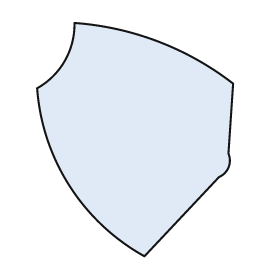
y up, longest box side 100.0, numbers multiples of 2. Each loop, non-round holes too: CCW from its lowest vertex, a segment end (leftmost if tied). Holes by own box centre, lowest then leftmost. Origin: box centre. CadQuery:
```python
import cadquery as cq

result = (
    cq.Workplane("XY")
    .moveTo(4.0, -50.0)
    .lineTo(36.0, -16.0)
    .threePointArc((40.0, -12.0), (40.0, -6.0))
    .lineTo(42.0, 24.0)
    .threePointArc((10.0, 42.0), (-26.0, 50.0))
    .threePointArc((-30.0, 34.0), (-42.0, 22.0))
    .threePointArc((-28.0, -20.0), (4.0, -50.0))
    .close()
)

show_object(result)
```